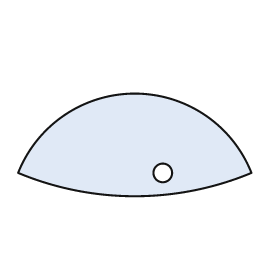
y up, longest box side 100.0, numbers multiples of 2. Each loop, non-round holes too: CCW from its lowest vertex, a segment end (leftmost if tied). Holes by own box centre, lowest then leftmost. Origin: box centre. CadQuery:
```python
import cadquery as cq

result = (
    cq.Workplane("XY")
    .moveTo(-50.0, -12.0)
    .threePointArc((0.0, -22.0), (50.0, -12.0))
    .threePointArc((0.0, 22.0), (-50.0, -12.0))
    .close()
    .moveTo(12.0, -12.0)
    .circle(4.0)
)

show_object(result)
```